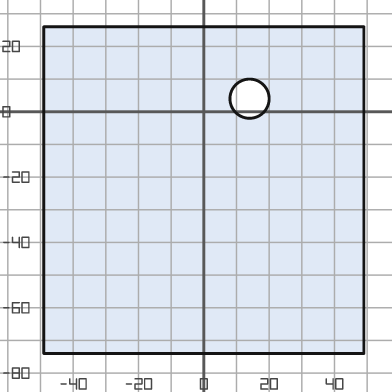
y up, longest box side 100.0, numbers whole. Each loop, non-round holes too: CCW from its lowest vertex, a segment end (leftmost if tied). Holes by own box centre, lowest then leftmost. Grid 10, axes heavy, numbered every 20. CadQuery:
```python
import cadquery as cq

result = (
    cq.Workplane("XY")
    .moveTo(-49.0, -74.0)
    .lineTo(49.0, -74.0)
    .lineTo(49.0, 26.0)
    .lineTo(-49.0, 26.0)
    .close()
    .moveTo(14.0, 4.0)
    .circle(6.0)
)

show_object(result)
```